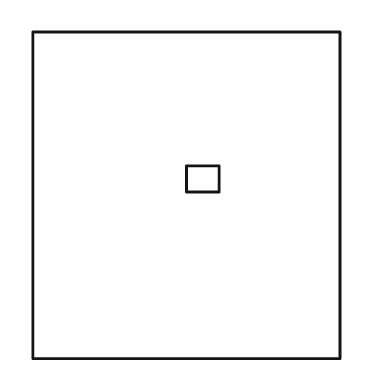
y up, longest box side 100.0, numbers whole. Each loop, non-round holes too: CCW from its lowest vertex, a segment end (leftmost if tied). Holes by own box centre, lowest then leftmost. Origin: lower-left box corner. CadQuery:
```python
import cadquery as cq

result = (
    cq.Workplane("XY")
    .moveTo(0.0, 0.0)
    .lineTo(94.0, 0.0)
    .lineTo(94.0, 100.0)
    .lineTo(0.0, 100.0)
    .close()
    .moveTo(47.0, 51.0)
    .lineTo(57.0, 51.0)
    .lineTo(57.0, 59.0)
    .lineTo(47.0, 59.0)
    .close()
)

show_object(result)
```